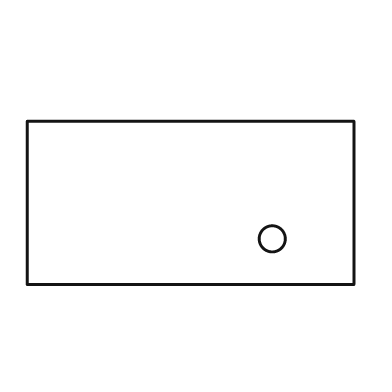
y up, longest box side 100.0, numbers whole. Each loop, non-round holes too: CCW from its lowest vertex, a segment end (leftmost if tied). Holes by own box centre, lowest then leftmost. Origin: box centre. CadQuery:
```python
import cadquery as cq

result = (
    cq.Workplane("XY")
    .moveTo(-50.0, -25.0)
    .lineTo(50.0, -25.0)
    .lineTo(50.0, 25.0)
    .lineTo(-50.0, 25.0)
    .close()
    .moveTo(25.0, -11.0)
    .circle(4.0)
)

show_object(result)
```